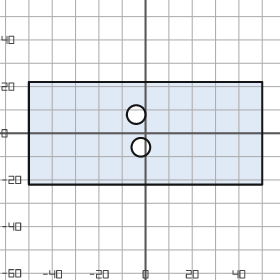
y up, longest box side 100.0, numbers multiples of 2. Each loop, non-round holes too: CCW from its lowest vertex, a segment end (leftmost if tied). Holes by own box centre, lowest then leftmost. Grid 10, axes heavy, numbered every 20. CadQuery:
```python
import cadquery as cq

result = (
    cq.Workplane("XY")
    .moveTo(-50.0, -22.0)
    .lineTo(50.0, -22.0)
    .lineTo(50.0, 22.0)
    .lineTo(-50.0, 22.0)
    .close()
    .moveTo(-2.0, -6.0)
    .circle(4.0)
    .moveTo(-4.0, 8.0)
    .circle(4.0)
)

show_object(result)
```